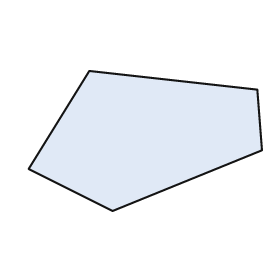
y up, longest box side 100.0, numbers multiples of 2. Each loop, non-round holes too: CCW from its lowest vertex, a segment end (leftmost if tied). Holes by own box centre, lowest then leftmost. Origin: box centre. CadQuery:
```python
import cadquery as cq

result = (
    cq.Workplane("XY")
    .moveTo(-14.0, -30.0)
    .lineTo(50.0, -4.0)
    .lineTo(48.0, 22.0)
    .lineTo(-24.0, 30.0)
    .lineTo(-50.0, -12.0)
    .close()
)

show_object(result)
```